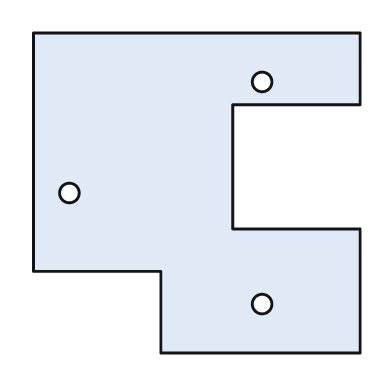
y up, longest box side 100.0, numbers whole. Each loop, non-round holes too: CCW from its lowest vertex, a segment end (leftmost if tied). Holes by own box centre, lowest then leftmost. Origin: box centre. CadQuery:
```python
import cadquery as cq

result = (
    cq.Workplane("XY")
    .moveTo(-11.0, -49.0)
    .lineTo(50.0, -49.0)
    .lineTo(50.0, -11.0)
    .lineTo(11.0, -11.0)
    .lineTo(11.0, 27.0)
    .lineTo(50.0, 27.0)
    .lineTo(50.0, 49.0)
    .lineTo(-50.0, 49.0)
    .lineTo(-50.0, -24.0)
    .lineTo(-11.0, -24.0)
    .close()
    .moveTo(20.0, -34.0)
    .circle(3.0)
    .moveTo(-39.0, 0.0)
    .circle(3.0)
    .moveTo(20.0, 34.0)
    .circle(3.0)
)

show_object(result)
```